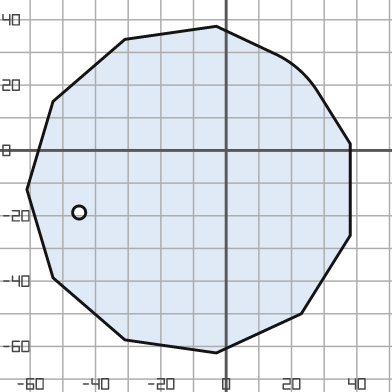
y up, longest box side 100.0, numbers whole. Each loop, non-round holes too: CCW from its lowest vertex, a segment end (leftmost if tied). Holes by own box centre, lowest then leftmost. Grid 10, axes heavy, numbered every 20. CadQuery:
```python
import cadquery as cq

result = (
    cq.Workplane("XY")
    .moveTo(-3.0, -62.0)
    .lineTo(23.0, -50.0)
    .lineTo(38.0, -26.0)
    .lineTo(38.0, 2.0)
    .lineTo(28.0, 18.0)
    .threePointArc((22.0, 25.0), (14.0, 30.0))
    .lineTo(-3.0, 38.0)
    .lineTo(-31.0, 34.0)
    .lineTo(-53.0, 15.0)
    .lineTo(-61.0, -12.0)
    .lineTo(-53.0, -39.0)
    .lineTo(-31.0, -58.0)
    .close()
    .moveTo(-45.0, -19.0)
    .circle(2.0)
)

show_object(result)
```